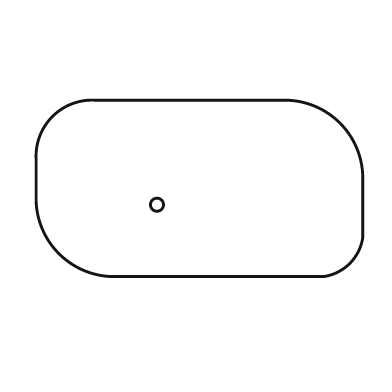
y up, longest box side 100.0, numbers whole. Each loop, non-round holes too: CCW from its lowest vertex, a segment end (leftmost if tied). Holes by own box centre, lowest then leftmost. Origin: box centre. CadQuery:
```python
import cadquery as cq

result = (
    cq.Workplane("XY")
    .moveTo(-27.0, -27.0)
    .lineTo(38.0, -27.0)
    .threePointArc((46.0, -23.0), (50.0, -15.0))
    .lineTo(50.0, 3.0)
    .threePointArc((43.0, 20.0), (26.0, 27.0))
    .lineTo(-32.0, 27.0)
    .threePointArc((-45.0, 22.0), (-50.0, 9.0))
    .lineTo(-50.0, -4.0)
    .threePointArc((-43.0, -20.0), (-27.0, -27.0))
    .close()
    .moveTo(-13.0, -5.0)
    .circle(2.0)
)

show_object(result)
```